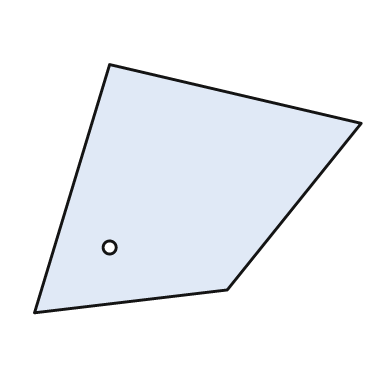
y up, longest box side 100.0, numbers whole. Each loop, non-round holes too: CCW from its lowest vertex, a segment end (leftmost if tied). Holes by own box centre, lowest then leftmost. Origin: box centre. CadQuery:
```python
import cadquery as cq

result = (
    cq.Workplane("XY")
    .moveTo(-50.0, -38.0)
    .lineTo(9.0, -31.0)
    .lineTo(50.0, 20.0)
    .lineTo(-27.0, 38.0)
    .close()
    .moveTo(-27.0, -18.0)
    .circle(2.0)
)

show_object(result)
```